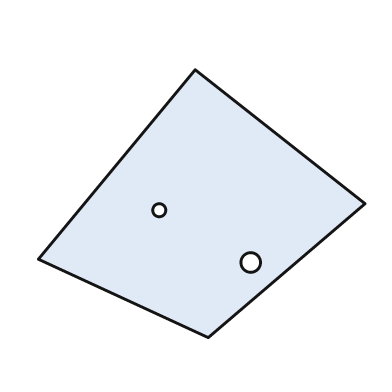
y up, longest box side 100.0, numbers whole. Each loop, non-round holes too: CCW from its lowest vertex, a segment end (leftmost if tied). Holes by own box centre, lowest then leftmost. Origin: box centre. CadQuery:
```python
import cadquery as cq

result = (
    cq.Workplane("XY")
    .moveTo(2.0, -41.0)
    .lineTo(50.0, 0.0)
    .lineTo(-2.0, 41.0)
    .lineTo(-50.0, -17.0)
    .close()
    .moveTo(15.0, -18.0)
    .circle(3.0)
    .moveTo(-13.0, -2.0)
    .circle(2.0)
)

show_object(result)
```